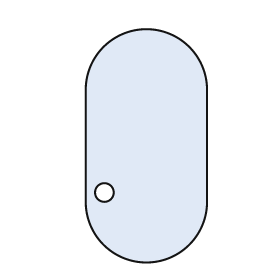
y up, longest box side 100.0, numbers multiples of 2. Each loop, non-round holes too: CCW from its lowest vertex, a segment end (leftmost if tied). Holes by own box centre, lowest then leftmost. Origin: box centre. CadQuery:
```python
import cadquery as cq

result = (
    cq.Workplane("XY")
    .moveTo(-26.0, -24.0)
    .threePointArc((0.0, -50.0), (26.0, -24.0))
    .lineTo(26.0, 24.0)
    .threePointArc((0.0, 50.0), (-26.0, 24.0))
    .close()
    .moveTo(-18.0, -20.0)
    .circle(4.0)
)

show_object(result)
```